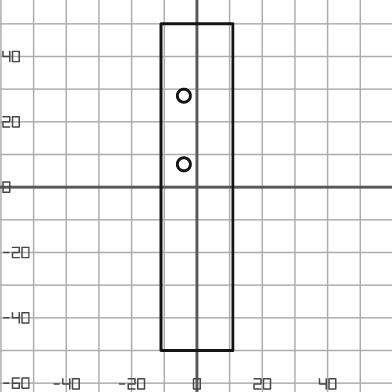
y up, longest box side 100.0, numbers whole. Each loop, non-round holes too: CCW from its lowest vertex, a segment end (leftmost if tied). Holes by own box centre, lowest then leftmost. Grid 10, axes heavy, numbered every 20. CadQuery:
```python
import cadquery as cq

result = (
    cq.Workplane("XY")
    .moveTo(-11.0, -50.0)
    .lineTo(11.0, -50.0)
    .lineTo(11.0, 50.0)
    .lineTo(-11.0, 50.0)
    .close()
    .moveTo(-4.0, 7.0)
    .circle(2.0)
    .moveTo(-4.0, 28.0)
    .circle(2.0)
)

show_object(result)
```